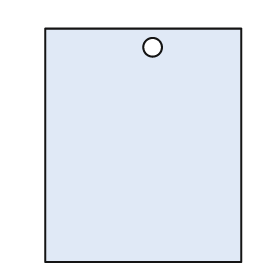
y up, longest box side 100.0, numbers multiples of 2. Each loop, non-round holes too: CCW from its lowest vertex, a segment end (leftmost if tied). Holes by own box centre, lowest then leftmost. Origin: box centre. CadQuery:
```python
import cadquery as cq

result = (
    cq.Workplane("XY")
    .moveTo(-42.0, -50.0)
    .lineTo(42.0, -50.0)
    .lineTo(42.0, 50.0)
    .lineTo(-42.0, 50.0)
    .close()
    .moveTo(4.0, 42.0)
    .circle(4.0)
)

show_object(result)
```